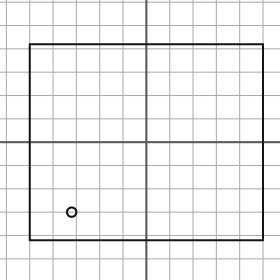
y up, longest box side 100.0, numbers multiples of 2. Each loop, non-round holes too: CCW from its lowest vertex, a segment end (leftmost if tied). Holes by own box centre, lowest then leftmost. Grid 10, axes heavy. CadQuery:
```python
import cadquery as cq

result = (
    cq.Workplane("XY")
    .moveTo(-50.0, -42.0)
    .lineTo(50.0, -42.0)
    .lineTo(50.0, 42.0)
    .lineTo(-50.0, 42.0)
    .close()
    .moveTo(-32.0, -30.0)
    .circle(2.0)
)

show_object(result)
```